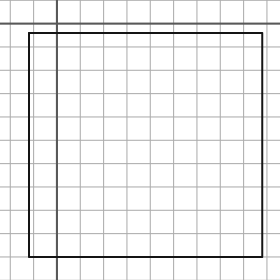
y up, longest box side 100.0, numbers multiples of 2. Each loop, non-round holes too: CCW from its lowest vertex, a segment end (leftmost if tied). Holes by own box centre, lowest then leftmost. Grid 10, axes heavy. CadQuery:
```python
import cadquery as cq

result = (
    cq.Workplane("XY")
    .moveTo(-12.0, -100.0)
    .lineTo(88.0, -100.0)
    .lineTo(88.0, -4.0)
    .lineTo(-12.0, -4.0)
    .close()
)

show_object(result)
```